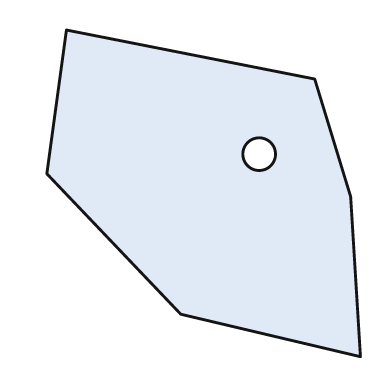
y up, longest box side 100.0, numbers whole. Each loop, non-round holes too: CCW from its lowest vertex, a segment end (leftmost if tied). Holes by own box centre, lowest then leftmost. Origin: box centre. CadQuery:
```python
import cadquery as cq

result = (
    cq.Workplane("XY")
    .moveTo(48.0, -50.0)
    .lineTo(45.0, -1.0)
    .lineTo(34.0, 35.0)
    .lineTo(-42.0, 50.0)
    .lineTo(-48.0, 6.0)
    .lineTo(-7.0, -37.0)
    .close()
    .moveTo(17.0, 12.0)
    .circle(5.0)
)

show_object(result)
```